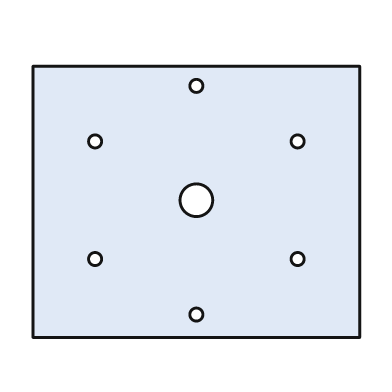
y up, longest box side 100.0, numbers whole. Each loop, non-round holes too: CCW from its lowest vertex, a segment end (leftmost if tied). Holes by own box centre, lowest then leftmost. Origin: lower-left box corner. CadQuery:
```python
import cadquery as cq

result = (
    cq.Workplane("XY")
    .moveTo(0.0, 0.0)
    .lineTo(100.0, 0.0)
    .lineTo(100.0, 83.0)
    .lineTo(0.0, 83.0)
    .close()
    .moveTo(50.0, 7.0)
    .circle(2.0)
    .moveTo(19.0, 24.0)
    .circle(2.0)
    .moveTo(81.0, 24.0)
    .circle(2.0)
    .moveTo(50.0, 42.0)
    .circle(5.0)
    .moveTo(19.0, 60.0)
    .circle(2.0)
    .moveTo(81.0, 60.0)
    .circle(2.0)
    .moveTo(50.0, 77.0)
    .circle(2.0)
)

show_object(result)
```